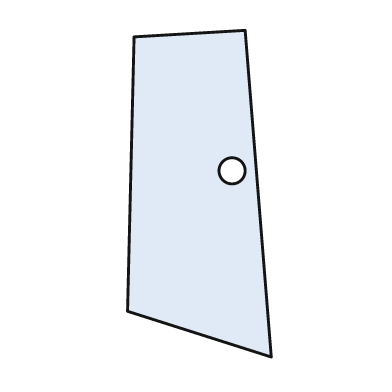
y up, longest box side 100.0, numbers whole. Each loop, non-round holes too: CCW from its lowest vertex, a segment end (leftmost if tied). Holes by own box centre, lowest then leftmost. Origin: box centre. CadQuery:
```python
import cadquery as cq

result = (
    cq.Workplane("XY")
    .moveTo(22.0, -50.0)
    .lineTo(14.0, 50.0)
    .lineTo(-20.0, 48.0)
    .lineTo(-22.0, -36.0)
    .close()
    .moveTo(10.0, 7.0)
    .circle(4.0)
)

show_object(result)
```